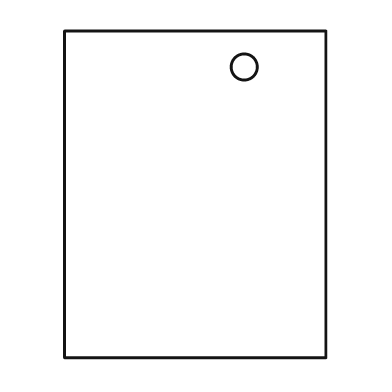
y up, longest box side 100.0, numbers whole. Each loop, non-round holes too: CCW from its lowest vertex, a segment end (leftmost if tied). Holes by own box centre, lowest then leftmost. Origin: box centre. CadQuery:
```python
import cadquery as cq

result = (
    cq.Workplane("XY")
    .moveTo(-40.0, -50.0)
    .lineTo(40.0, -50.0)
    .lineTo(40.0, 50.0)
    .lineTo(-40.0, 50.0)
    .close()
    .moveTo(15.0, 39.0)
    .circle(4.0)
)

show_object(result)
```